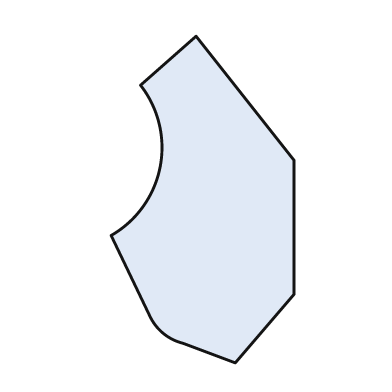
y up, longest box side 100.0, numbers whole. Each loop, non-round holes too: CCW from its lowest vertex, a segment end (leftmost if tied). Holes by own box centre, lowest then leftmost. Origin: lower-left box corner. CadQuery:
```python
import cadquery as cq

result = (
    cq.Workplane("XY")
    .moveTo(38.0, 0.0)
    .lineTo(56.0, 21.0)
    .lineTo(56.0, 62.0)
    .lineTo(26.0, 100.0)
    .lineTo(9.0, 85.0)
    .threePointArc((15.0, 60.0), (0.0, 39.0))
    .lineTo(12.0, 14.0)
    .threePointArc((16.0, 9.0), (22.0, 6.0))
    .close()
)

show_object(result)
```